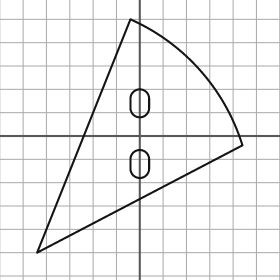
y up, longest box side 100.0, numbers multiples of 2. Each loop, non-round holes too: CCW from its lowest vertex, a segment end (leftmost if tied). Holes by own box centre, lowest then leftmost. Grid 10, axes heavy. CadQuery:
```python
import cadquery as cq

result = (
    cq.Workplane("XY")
    .moveTo(-44.0, -50.0)
    .lineTo(44.0, -4.0)
    .threePointArc((26.0, 28.0), (-4.0, 50.0))
    .close()
    .moveTo(-4.0, -14.0)
    .threePointArc((0.0, -18.0), (4.0, -14.0))
    .lineTo(4.0, -10.0)
    .threePointArc((0.0, -6.0), (-4.0, -10.0))
    .close()
    .moveTo(-4.0, 12.0)
    .threePointArc((0.0, 8.0), (4.0, 12.0))
    .lineTo(4.0, 16.0)
    .threePointArc((0.0, 20.0), (-4.0, 16.0))
    .close()
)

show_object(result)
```